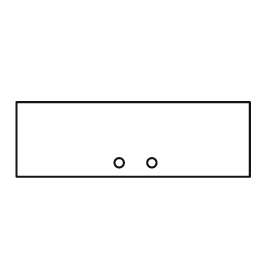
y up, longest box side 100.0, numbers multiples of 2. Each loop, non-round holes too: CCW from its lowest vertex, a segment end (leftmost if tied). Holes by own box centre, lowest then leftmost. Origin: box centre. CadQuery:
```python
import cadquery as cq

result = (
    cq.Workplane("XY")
    .moveTo(-50.0, -16.0)
    .lineTo(50.0, -16.0)
    .lineTo(50.0, 16.0)
    .lineTo(-50.0, 16.0)
    .close()
    .moveTo(-6.0, -10.0)
    .circle(2.0)
    .moveTo(8.0, -10.0)
    .circle(2.0)
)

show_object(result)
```